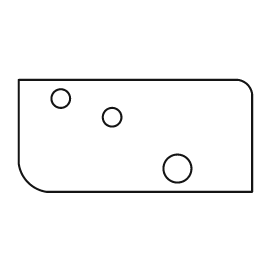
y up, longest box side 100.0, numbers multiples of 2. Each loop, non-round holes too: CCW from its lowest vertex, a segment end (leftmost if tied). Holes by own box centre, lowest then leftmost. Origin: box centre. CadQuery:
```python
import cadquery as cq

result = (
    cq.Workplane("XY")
    .moveTo(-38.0, -24.0)
    .lineTo(50.0, -24.0)
    .lineTo(50.0, 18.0)
    .threePointArc((48.0, 22.0), (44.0, 24.0))
    .lineTo(-50.0, 24.0)
    .lineTo(-50.0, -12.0)
    .threePointArc((-46.0, -20.0), (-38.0, -24.0))
    .close()
    .moveTo(18.0, -14.0)
    .circle(6.0)
    .moveTo(-10.0, 8.0)
    .circle(4.0)
    .moveTo(-32.0, 16.0)
    .circle(4.0)
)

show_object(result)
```